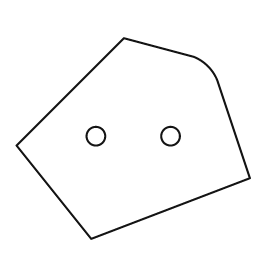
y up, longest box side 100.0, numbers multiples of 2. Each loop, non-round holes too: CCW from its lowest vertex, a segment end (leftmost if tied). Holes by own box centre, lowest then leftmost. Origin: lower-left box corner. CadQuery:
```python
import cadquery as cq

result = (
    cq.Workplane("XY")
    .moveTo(32.0, 0.0)
    .lineTo(100.0, 26.0)
    .lineTo(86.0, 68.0)
    .threePointArc((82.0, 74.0), (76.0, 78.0))
    .lineTo(46.0, 86.0)
    .lineTo(0.0, 40.0)
    .close()
    .moveTo(34.0, 44.0)
    .circle(4.0)
    .moveTo(66.0, 44.0)
    .circle(4.0)
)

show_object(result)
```